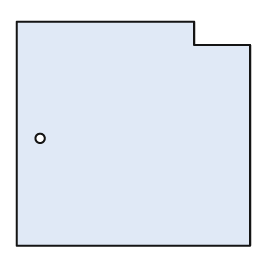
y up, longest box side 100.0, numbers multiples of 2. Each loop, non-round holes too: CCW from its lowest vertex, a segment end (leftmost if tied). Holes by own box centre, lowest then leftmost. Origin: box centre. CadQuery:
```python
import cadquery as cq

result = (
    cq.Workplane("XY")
    .moveTo(-50.0, -48.0)
    .lineTo(50.0, -48.0)
    .lineTo(50.0, 38.0)
    .lineTo(26.0, 38.0)
    .lineTo(26.0, 48.0)
    .lineTo(-50.0, 48.0)
    .close()
    .moveTo(-40.0, -2.0)
    .circle(2.0)
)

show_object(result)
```